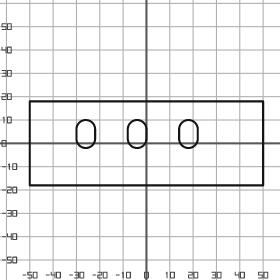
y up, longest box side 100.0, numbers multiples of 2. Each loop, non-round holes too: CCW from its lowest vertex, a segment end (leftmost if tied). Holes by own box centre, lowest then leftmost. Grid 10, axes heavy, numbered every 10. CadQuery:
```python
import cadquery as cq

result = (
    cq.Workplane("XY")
    .moveTo(-50.0, -18.0)
    .lineTo(50.0, -18.0)
    .lineTo(50.0, 18.0)
    .lineTo(-50.0, 18.0)
    .close()
    .moveTo(-30.0, 2.0)
    .threePointArc((-26.0, -2.0), (-22.0, 2.0))
    .lineTo(-22.0, 6.0)
    .threePointArc((-26.0, 10.0), (-30.0, 6.0))
    .close()
    .moveTo(-8.0, 2.0)
    .threePointArc((-4.0, -2.0), (0.0, 2.0))
    .lineTo(0.0, 6.0)
    .threePointArc((-4.0, 10.0), (-8.0, 6.0))
    .close()
    .moveTo(14.0, 2.0)
    .threePointArc((18.0, -2.0), (22.0, 2.0))
    .lineTo(22.0, 6.0)
    .threePointArc((18.0, 10.0), (14.0, 6.0))
    .close()
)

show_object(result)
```